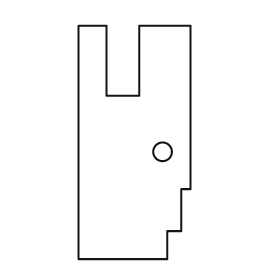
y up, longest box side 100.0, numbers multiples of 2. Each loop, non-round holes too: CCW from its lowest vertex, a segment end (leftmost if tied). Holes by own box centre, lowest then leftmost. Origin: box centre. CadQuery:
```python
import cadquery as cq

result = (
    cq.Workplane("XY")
    .moveTo(-24.0, -50.0)
    .lineTo(14.0, -50.0)
    .lineTo(14.0, -38.0)
    .lineTo(20.0, -38.0)
    .lineTo(20.0, -20.0)
    .lineTo(24.0, -20.0)
    .lineTo(24.0, 50.0)
    .lineTo(2.0, 50.0)
    .lineTo(2.0, 20.0)
    .lineTo(-12.0, 20.0)
    .lineTo(-12.0, 50.0)
    .lineTo(-24.0, 50.0)
    .close()
    .moveTo(12.0, -4.0)
    .circle(4.0)
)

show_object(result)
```